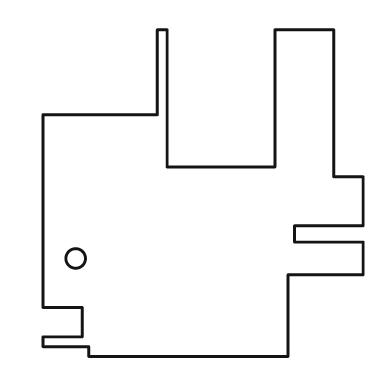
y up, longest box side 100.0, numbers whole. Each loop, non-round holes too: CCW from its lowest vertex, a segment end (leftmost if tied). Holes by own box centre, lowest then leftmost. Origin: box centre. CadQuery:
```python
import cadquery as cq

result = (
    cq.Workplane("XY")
    .moveTo(-35.0, -50.0)
    .lineTo(26.0, -50.0)
    .lineTo(26.0, -25.0)
    .lineTo(49.0, -25.0)
    .lineTo(49.0, -15.0)
    .lineTo(28.0, -15.0)
    .lineTo(28.0, -10.0)
    .lineTo(49.0, -10.0)
    .lineTo(49.0, 5.0)
    .lineTo(40.0, 5.0)
    .lineTo(40.0, 50.0)
    .lineTo(22.0, 50.0)
    .lineTo(22.0, 8.0)
    .lineTo(-11.0, 8.0)
    .lineTo(-11.0, 50.0)
    .lineTo(-14.0, 50.0)
    .lineTo(-14.0, 24.0)
    .lineTo(-49.0, 24.0)
    .lineTo(-49.0, -35.0)
    .lineTo(-37.0, -35.0)
    .lineTo(-37.0, -44.0)
    .lineTo(-49.0, -44.0)
    .lineTo(-49.0, -47.0)
    .lineTo(-35.0, -47.0)
    .close()
    .moveTo(-39.0, -20.0)
    .circle(3.0)
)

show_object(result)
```